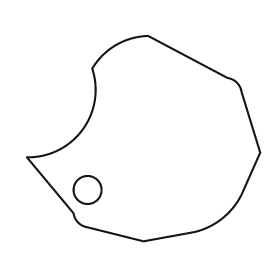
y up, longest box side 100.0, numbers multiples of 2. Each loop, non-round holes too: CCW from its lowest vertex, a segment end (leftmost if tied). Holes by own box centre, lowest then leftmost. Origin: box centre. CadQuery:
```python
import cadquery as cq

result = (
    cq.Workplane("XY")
    .moveTo(0.0, -44.0)
    .lineTo(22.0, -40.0)
    .threePointArc((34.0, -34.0), (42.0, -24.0))
    .lineTo(50.0, -6.0)
    .lineTo(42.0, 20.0)
    .threePointArc((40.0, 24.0), (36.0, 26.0))
    .lineTo(2.0, 44.0)
    .threePointArc((-12.0, 40.0), (-22.0, 30.0))
    .threePointArc((-26.0, 4.0), (-50.0, -8.0))
    .lineTo(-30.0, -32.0)
    .threePointArc((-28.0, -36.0), (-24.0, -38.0))
    .close()
    .moveTo(-24.0, -22.0)
    .circle(6.0)
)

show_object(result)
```